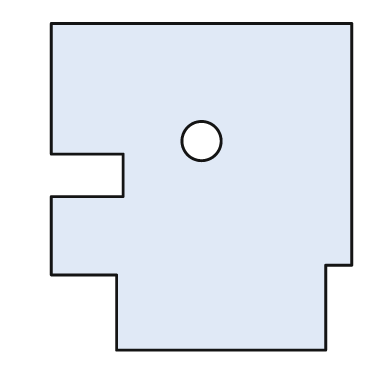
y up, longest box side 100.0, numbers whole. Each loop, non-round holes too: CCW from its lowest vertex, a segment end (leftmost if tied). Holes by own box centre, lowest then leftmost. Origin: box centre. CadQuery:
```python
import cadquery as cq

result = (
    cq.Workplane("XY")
    .moveTo(-26.0, -50.0)
    .lineTo(38.0, -50.0)
    .lineTo(38.0, -24.0)
    .lineTo(46.0, -24.0)
    .lineTo(46.0, 50.0)
    .lineTo(-46.0, 50.0)
    .lineTo(-46.0, 10.0)
    .lineTo(-24.0, 10.0)
    .lineTo(-24.0, -3.0)
    .lineTo(-46.0, -3.0)
    .lineTo(-46.0, -27.0)
    .lineTo(-26.0, -27.0)
    .close()
    .moveTo(0.0, 14.0)
    .circle(6.0)
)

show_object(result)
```